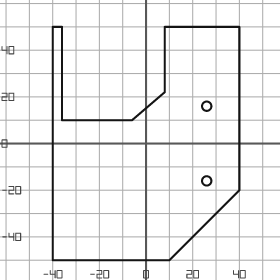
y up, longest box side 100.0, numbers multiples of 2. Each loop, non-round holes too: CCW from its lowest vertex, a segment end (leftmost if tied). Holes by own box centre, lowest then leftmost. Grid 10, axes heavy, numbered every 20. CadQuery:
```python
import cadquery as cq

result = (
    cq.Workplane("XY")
    .moveTo(-40.0, -50.0)
    .lineTo(10.0, -50.0)
    .lineTo(40.0, -20.0)
    .lineTo(40.0, 50.0)
    .lineTo(8.0, 50.0)
    .lineTo(8.0, 22.0)
    .lineTo(-6.0, 10.0)
    .lineTo(-36.0, 10.0)
    .lineTo(-36.0, 50.0)
    .lineTo(-40.0, 50.0)
    .close()
    .moveTo(26.0, -16.0)
    .circle(2.0)
    .moveTo(26.0, 16.0)
    .circle(2.0)
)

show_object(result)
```